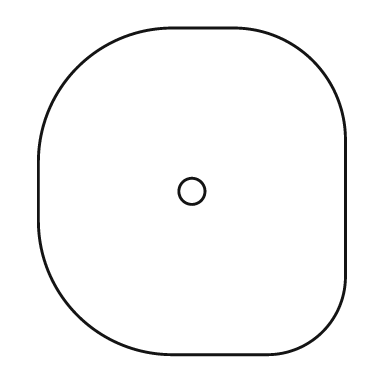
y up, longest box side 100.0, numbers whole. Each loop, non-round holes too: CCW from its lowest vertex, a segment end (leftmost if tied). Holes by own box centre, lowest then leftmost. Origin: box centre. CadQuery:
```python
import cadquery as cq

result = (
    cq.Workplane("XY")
    .moveTo(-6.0, -50.0)
    .lineTo(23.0, -50.0)
    .threePointArc((40.0, -43.0), (47.0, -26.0))
    .lineTo(47.0, 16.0)
    .threePointArc((37.0, 40.0), (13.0, 50.0))
    .lineTo(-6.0, 50.0)
    .threePointArc((-35.0, 38.0), (-47.0, 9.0))
    .lineTo(-47.0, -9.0)
    .threePointArc((-35.0, -38.0), (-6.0, -50.0))
    .close()
    .moveTo(0.0, 0.0)
    .circle(4.0)
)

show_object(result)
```